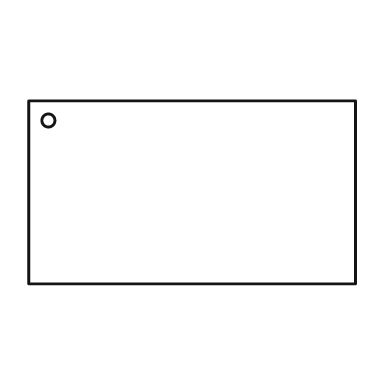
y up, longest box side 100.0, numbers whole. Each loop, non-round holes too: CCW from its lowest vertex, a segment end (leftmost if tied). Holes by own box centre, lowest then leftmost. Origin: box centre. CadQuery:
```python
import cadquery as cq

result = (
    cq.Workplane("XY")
    .moveTo(-50.0, -28.0)
    .lineTo(50.0, -28.0)
    .lineTo(50.0, 28.0)
    .lineTo(-50.0, 28.0)
    .close()
    .moveTo(-44.0, 22.0)
    .circle(2.0)
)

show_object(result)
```